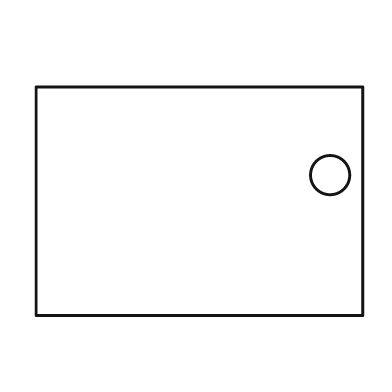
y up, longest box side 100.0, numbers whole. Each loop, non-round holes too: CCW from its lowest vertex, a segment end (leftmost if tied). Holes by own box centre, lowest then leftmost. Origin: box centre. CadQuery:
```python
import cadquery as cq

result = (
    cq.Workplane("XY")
    .moveTo(-50.0, -35.0)
    .lineTo(50.0, -35.0)
    .lineTo(50.0, 35.0)
    .lineTo(-50.0, 35.0)
    .close()
    .moveTo(40.0, 8.0)
    .circle(6.0)
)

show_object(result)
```